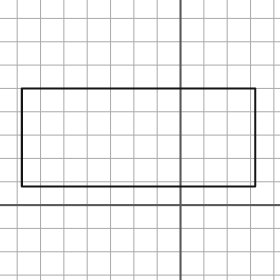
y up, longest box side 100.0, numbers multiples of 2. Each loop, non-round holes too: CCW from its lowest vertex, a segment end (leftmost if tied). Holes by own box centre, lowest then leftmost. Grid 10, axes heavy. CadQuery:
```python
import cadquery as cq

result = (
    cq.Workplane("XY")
    .moveTo(-68.0, 8.0)
    .lineTo(32.0, 8.0)
    .lineTo(32.0, 50.0)
    .lineTo(-68.0, 50.0)
    .close()
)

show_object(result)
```